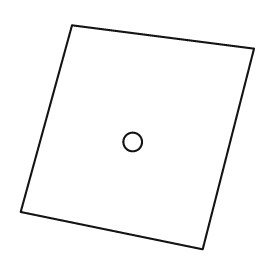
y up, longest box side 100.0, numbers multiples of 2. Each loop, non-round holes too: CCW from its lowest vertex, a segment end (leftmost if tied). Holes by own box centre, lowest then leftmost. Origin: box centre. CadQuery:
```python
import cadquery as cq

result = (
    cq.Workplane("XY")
    .moveTo(28.0, -48.0)
    .lineTo(50.0, 38.0)
    .lineTo(-28.0, 48.0)
    .lineTo(-50.0, -32.0)
    .close()
    .moveTo(-2.0, -2.0)
    .circle(4.0)
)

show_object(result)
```